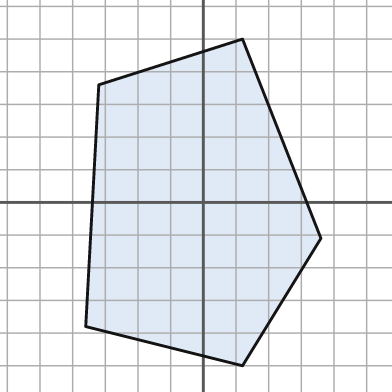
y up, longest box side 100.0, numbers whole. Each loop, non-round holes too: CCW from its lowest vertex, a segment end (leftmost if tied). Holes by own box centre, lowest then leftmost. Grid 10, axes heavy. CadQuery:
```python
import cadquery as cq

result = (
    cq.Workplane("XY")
    .moveTo(12.0, -50.0)
    .lineTo(36.0, -11.0)
    .lineTo(12.0, 50.0)
    .lineTo(-32.0, 36.0)
    .lineTo(-36.0, -38.0)
    .close()
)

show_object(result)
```